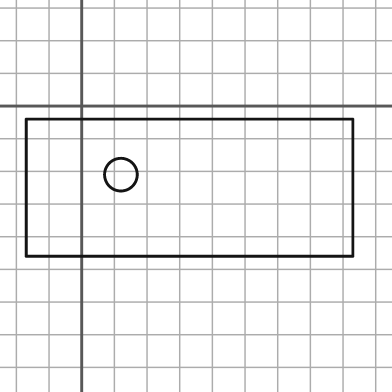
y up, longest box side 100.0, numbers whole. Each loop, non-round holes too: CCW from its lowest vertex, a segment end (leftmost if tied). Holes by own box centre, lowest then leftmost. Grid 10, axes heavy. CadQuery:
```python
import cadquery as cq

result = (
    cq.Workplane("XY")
    .moveTo(-17.0, -46.0)
    .lineTo(83.0, -46.0)
    .lineTo(83.0, -4.0)
    .lineTo(-17.0, -4.0)
    .close()
    .moveTo(12.0, -21.0)
    .circle(5.0)
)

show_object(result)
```